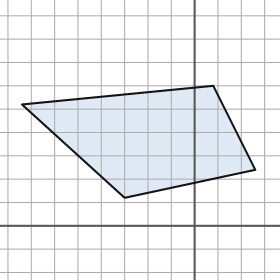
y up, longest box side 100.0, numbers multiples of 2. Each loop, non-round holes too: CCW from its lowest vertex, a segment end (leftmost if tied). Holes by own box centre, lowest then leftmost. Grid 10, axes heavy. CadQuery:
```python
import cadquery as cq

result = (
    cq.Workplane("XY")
    .moveTo(-30.0, 12.0)
    .lineTo(26.0, 24.0)
    .lineTo(8.0, 60.0)
    .lineTo(-74.0, 52.0)
    .close()
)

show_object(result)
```